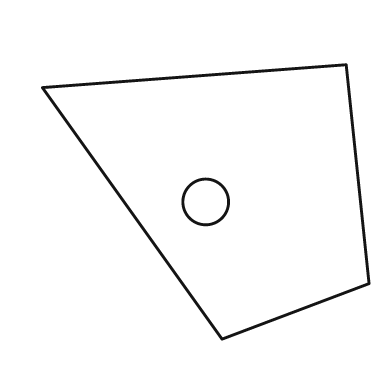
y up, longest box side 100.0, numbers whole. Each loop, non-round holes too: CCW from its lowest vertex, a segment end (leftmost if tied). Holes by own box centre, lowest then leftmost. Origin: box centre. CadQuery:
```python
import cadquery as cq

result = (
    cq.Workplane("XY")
    .moveTo(5.0, -42.0)
    .lineTo(50.0, -25.0)
    .lineTo(43.0, 42.0)
    .lineTo(-50.0, 35.0)
    .close()
    .moveTo(0.0, 0.0)
    .circle(7.0)
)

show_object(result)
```